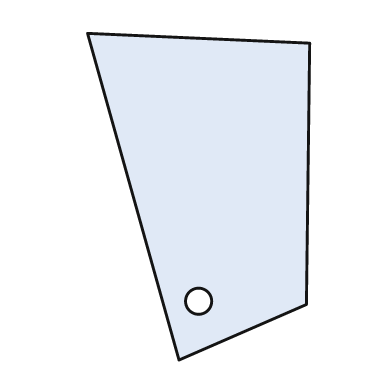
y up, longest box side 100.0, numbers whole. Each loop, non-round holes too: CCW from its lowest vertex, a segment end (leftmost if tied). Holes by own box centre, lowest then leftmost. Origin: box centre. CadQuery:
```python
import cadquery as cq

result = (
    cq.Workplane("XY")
    .moveTo(-6.0, -50.0)
    .lineTo(33.0, -33.0)
    .lineTo(34.0, 47.0)
    .lineTo(-34.0, 50.0)
    .close()
    .moveTo(0.0, -32.0)
    .circle(4.0)
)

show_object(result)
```